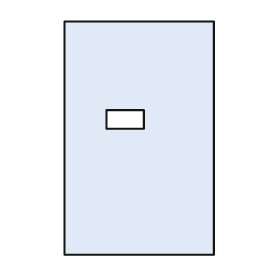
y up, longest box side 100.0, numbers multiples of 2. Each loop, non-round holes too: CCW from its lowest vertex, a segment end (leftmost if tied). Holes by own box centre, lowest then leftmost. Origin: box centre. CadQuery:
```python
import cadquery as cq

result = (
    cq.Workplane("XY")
    .moveTo(-32.0, -50.0)
    .lineTo(32.0, -50.0)
    .lineTo(32.0, 50.0)
    .lineTo(-32.0, 50.0)
    .close()
    .moveTo(-14.0, 4.0)
    .lineTo(2.0, 4.0)
    .lineTo(2.0, 12.0)
    .lineTo(-14.0, 12.0)
    .close()
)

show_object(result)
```